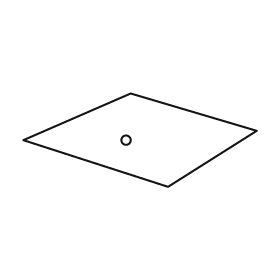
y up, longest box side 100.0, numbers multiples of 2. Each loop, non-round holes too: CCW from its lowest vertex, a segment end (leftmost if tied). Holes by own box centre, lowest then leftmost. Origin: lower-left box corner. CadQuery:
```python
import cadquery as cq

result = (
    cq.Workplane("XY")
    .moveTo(62.0, 0.0)
    .lineTo(100.0, 24.0)
    .lineTo(46.0, 40.0)
    .lineTo(0.0, 20.0)
    .close()
    .moveTo(44.0, 20.0)
    .circle(2.0)
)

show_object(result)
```